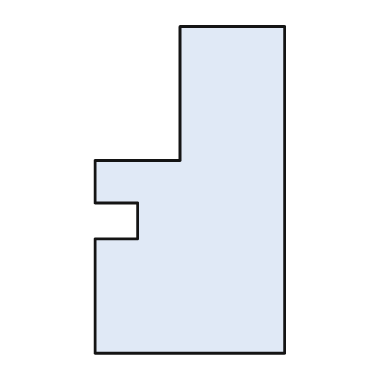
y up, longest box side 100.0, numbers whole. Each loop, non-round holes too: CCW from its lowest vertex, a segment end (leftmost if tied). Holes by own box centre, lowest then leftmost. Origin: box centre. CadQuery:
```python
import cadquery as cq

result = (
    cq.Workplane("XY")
    .moveTo(-29.0, -50.0)
    .lineTo(29.0, -50.0)
    .lineTo(29.0, 50.0)
    .lineTo(-3.0, 50.0)
    .lineTo(-3.0, 9.0)
    .lineTo(-29.0, 9.0)
    .lineTo(-29.0, -4.0)
    .lineTo(-16.0, -4.0)
    .lineTo(-16.0, -15.0)
    .lineTo(-29.0, -15.0)
    .close()
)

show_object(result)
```